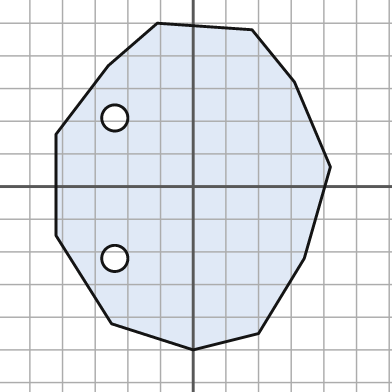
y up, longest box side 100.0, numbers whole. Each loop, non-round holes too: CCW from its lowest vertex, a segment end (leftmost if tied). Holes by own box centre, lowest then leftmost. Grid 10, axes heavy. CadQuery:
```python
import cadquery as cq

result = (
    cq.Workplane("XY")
    .moveTo(0.0, -50.0)
    .lineTo(20.0, -45.0)
    .lineTo(34.0, -22.0)
    .lineTo(42.0, 6.0)
    .lineTo(31.0, 32.0)
    .lineTo(18.0, 48.0)
    .lineTo(-11.0, 50.0)
    .lineTo(-26.0, 37.0)
    .lineTo(-42.0, 16.0)
    .lineTo(-42.0, -15.0)
    .lineTo(-25.0, -42.0)
    .close()
    .moveTo(-24.0, -22.0)
    .circle(4.0)
    .moveTo(-24.0, 21.0)
    .circle(4.0)
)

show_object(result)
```